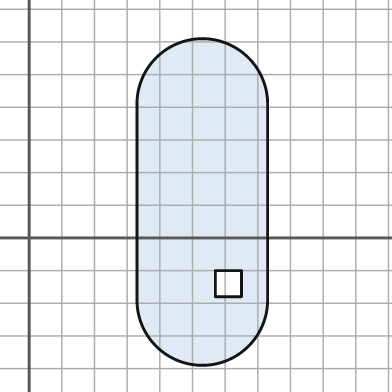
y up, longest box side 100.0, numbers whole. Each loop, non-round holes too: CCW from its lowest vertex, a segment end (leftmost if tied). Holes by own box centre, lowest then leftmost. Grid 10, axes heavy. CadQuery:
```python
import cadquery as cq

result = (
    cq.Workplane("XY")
    .moveTo(33.0, -19.0)
    .threePointArc((53.0, -39.0), (73.0, -19.0))
    .lineTo(73.0, 41.0)
    .threePointArc((53.0, 61.0), (33.0, 41.0))
    .close()
    .moveTo(57.0, -18.0)
    .lineTo(65.0, -18.0)
    .lineTo(65.0, -10.0)
    .lineTo(57.0, -10.0)
    .close()
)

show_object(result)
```